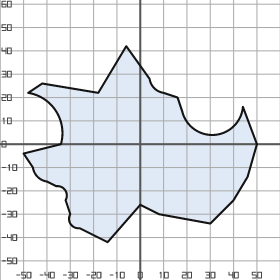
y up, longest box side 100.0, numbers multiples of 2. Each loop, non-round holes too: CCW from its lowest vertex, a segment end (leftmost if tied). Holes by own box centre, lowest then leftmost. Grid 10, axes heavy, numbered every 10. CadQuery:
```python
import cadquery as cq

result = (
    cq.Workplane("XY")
    .moveTo(-14.0, -42.0)
    .lineTo(0.0, -26.0)
    .lineTo(8.0, -30.0)
    .lineTo(30.0, -34.0)
    .lineTo(40.0, -24.0)
    .lineTo(46.0, -14.0)
    .lineTo(50.0, 0.0)
    .lineTo(44.0, 16.0)
    .threePointArc((32.0, 4.0), (18.0, 14.0))
    .lineTo(16.0, 20.0)
    .lineTo(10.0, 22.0)
    .threePointArc((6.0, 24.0), (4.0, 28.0))
    .lineTo(-6.0, 42.0)
    .lineTo(-18.0, 22.0)
    .lineTo(-42.0, 26.0)
    .lineTo(-48.0, 22.0)
    .threePointArc((-36.0, 14.0), (-34.0, 0.0))
    .lineTo(-50.0, -4.0)
    .lineTo(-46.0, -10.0)
    .threePointArc((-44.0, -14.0), (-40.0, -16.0))
    .lineTo(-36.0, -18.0)
    .threePointArc((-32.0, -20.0), (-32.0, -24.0))
    .lineTo(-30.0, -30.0)
    .threePointArc((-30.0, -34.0), (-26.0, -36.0))
    .close()
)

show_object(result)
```